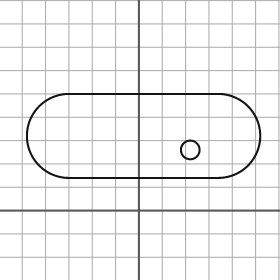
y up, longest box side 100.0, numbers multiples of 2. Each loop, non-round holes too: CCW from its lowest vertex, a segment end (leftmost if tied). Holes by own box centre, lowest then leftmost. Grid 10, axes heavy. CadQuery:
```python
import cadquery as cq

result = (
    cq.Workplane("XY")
    .moveTo(-30.0, 14.0)
    .lineTo(34.0, 14.0)
    .threePointArc((52.0, 32.0), (34.0, 50.0))
    .lineTo(-30.0, 50.0)
    .threePointArc((-48.0, 32.0), (-30.0, 14.0))
    .close()
    .moveTo(22.0, 26.0)
    .circle(4.0)
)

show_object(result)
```